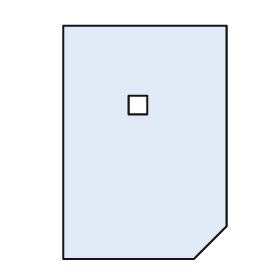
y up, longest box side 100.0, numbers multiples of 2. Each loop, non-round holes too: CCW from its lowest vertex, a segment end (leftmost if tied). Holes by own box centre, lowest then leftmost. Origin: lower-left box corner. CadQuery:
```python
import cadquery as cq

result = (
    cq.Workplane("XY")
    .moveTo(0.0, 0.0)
    .lineTo(56.0, 0.0)
    .lineTo(70.0, 14.0)
    .lineTo(70.0, 100.0)
    .lineTo(0.0, 100.0)
    .close()
    .moveTo(28.0, 62.0)
    .lineTo(36.0, 62.0)
    .lineTo(36.0, 70.0)
    .lineTo(28.0, 70.0)
    .close()
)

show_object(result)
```